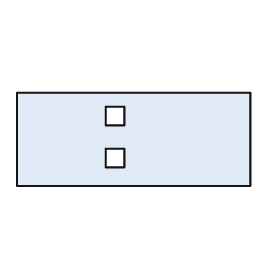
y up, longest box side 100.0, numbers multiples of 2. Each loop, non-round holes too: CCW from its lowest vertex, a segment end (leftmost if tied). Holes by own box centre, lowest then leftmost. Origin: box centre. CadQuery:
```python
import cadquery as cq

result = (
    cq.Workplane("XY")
    .moveTo(-50.0, -20.0)
    .lineTo(50.0, -20.0)
    .lineTo(50.0, 20.0)
    .lineTo(-50.0, 20.0)
    .close()
    .moveTo(-12.0, -12.0)
    .lineTo(-4.0, -12.0)
    .lineTo(-4.0, -4.0)
    .lineTo(-12.0, -4.0)
    .close()
    .moveTo(-12.0, 6.0)
    .lineTo(-4.0, 6.0)
    .lineTo(-4.0, 14.0)
    .lineTo(-12.0, 14.0)
    .close()
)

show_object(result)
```